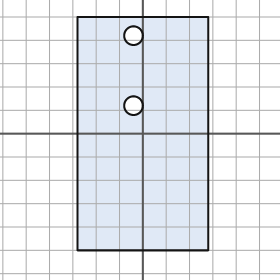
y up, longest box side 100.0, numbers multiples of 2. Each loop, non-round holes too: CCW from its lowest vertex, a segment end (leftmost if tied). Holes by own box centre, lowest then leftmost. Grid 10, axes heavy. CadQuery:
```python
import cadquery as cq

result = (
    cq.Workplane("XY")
    .moveTo(-28.0, -50.0)
    .lineTo(28.0, -50.0)
    .lineTo(28.0, 50.0)
    .lineTo(-28.0, 50.0)
    .close()
    .moveTo(-4.0, 12.0)
    .circle(4.0)
    .moveTo(-4.0, 42.0)
    .circle(4.0)
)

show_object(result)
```